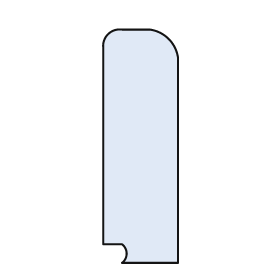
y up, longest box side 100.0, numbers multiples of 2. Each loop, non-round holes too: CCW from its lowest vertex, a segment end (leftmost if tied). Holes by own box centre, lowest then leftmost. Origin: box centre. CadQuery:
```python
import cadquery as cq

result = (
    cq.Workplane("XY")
    .moveTo(-8.0, -50.0)
    .lineTo(16.0, -50.0)
    .lineTo(16.0, 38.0)
    .threePointArc((12.0, 46.0), (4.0, 50.0))
    .lineTo(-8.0, 50.0)
    .threePointArc((-14.0, 48.0), (-16.0, 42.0))
    .lineTo(-16.0, -42.0)
    .lineTo(-8.0, -42.0)
    .threePointArc((-6.0, -46.0), (-8.0, -50.0))
    .close()
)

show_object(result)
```